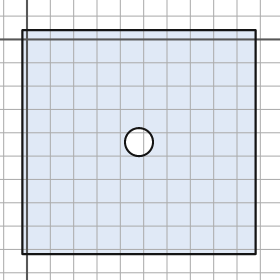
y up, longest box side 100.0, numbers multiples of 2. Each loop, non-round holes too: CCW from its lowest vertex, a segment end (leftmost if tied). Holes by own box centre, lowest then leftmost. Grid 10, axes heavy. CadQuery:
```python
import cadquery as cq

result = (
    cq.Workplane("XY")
    .moveTo(-2.0, -92.0)
    .lineTo(98.0, -92.0)
    .lineTo(98.0, 4.0)
    .lineTo(-2.0, 4.0)
    .close()
    .moveTo(48.0, -44.0)
    .circle(6.0)
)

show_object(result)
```